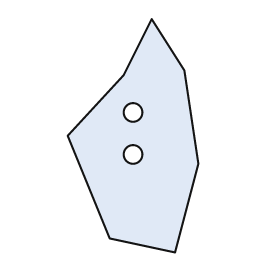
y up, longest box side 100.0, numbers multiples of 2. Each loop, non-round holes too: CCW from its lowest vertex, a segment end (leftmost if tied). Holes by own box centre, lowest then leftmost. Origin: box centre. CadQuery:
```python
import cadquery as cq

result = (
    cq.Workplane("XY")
    .moveTo(18.0, -50.0)
    .lineTo(28.0, -12.0)
    .lineTo(22.0, 28.0)
    .lineTo(8.0, 50.0)
    .lineTo(-4.0, 26.0)
    .lineTo(-28.0, 0.0)
    .lineTo(-10.0, -44.0)
    .close()
    .moveTo(0.0, -8.0)
    .circle(4.0)
    .moveTo(0.0, 10.0)
    .circle(4.0)
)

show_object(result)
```